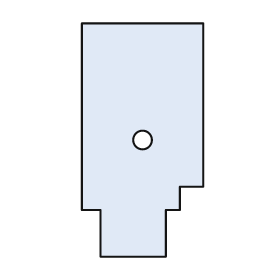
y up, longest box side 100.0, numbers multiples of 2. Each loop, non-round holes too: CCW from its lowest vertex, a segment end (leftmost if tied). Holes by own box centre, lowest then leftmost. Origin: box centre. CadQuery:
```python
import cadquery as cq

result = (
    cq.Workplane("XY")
    .moveTo(-18.0, -50.0)
    .lineTo(10.0, -50.0)
    .lineTo(10.0, -30.0)
    .lineTo(16.0, -30.0)
    .lineTo(16.0, -20.0)
    .lineTo(26.0, -20.0)
    .lineTo(26.0, 50.0)
    .lineTo(-26.0, 50.0)
    .lineTo(-26.0, -30.0)
    .lineTo(-18.0, -30.0)
    .close()
    .moveTo(0.0, 0.0)
    .circle(4.0)
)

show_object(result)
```